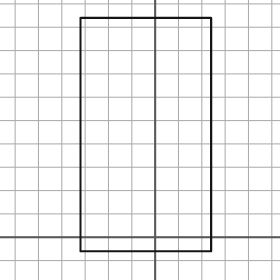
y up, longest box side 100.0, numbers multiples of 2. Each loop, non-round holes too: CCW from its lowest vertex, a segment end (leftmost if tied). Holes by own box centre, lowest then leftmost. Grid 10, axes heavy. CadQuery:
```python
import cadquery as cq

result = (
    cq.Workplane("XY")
    .moveTo(-32.0, -6.0)
    .lineTo(24.0, -6.0)
    .lineTo(24.0, 94.0)
    .lineTo(-32.0, 94.0)
    .close()
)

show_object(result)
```